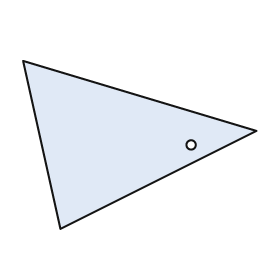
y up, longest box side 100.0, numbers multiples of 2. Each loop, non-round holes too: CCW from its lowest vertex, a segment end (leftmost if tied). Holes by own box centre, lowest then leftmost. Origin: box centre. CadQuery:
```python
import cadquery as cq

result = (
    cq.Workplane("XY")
    .moveTo(-34.0, -36.0)
    .lineTo(50.0, 6.0)
    .lineTo(-50.0, 36.0)
    .close()
    .moveTo(22.0, 0.0)
    .circle(2.0)
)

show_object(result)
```